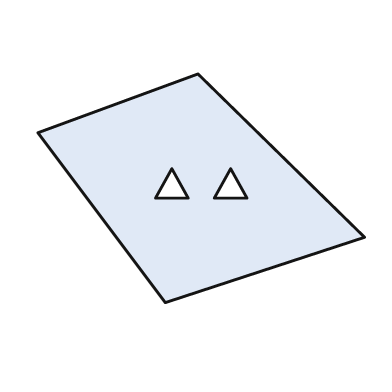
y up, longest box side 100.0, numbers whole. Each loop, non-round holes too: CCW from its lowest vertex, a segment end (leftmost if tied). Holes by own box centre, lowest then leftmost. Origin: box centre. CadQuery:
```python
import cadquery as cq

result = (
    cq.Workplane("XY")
    .moveTo(-11.0, -35.0)
    .lineTo(50.0, -15.0)
    .lineTo(-1.0, 35.0)
    .lineTo(-50.0, 17.0)
    .close()
    .moveTo(-14.0, -3.0)
    .lineTo(-4.0, -3.0)
    .lineTo(-9.0, 6.0)
    .close()
    .moveTo(4.0, -3.0)
    .lineTo(14.0, -3.0)
    .lineTo(9.0, 6.0)
    .close()
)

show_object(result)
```